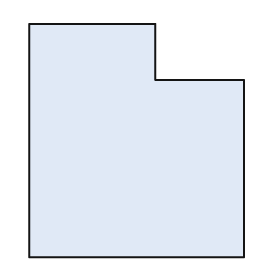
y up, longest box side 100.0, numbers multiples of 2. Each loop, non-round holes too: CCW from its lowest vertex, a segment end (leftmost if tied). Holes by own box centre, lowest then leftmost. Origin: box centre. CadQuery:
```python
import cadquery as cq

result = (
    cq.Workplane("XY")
    .moveTo(-46.0, -50.0)
    .lineTo(46.0, -50.0)
    .lineTo(46.0, 26.0)
    .lineTo(8.0, 26.0)
    .lineTo(8.0, 50.0)
    .lineTo(-46.0, 50.0)
    .close()
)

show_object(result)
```